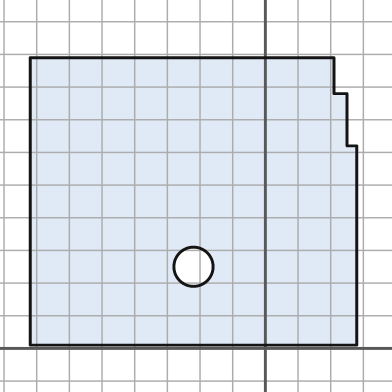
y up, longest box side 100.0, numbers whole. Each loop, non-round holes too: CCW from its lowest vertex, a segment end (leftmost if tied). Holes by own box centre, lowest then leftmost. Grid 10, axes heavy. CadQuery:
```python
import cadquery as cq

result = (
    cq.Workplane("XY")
    .moveTo(-72.0, 1.0)
    .lineTo(28.0, 1.0)
    .lineTo(28.0, 62.0)
    .lineTo(25.0, 62.0)
    .lineTo(25.0, 78.0)
    .lineTo(21.0, 78.0)
    .lineTo(21.0, 89.0)
    .lineTo(-72.0, 89.0)
    .close()
    .moveTo(-22.0, 25.0)
    .circle(6.0)
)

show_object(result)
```